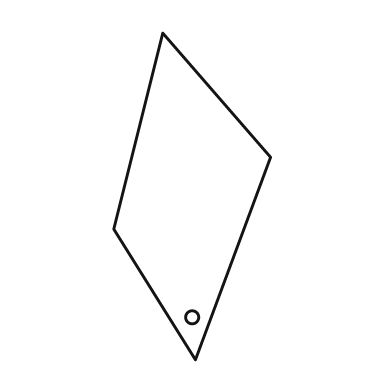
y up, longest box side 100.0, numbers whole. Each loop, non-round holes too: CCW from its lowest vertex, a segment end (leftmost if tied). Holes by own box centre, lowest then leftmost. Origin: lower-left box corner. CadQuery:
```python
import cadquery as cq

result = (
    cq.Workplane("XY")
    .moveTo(25.0, 0.0)
    .lineTo(48.0, 62.0)
    .lineTo(15.0, 100.0)
    .lineTo(0.0, 40.0)
    .close()
    .moveTo(24.0, 13.0)
    .circle(2.0)
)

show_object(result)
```